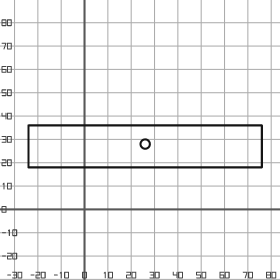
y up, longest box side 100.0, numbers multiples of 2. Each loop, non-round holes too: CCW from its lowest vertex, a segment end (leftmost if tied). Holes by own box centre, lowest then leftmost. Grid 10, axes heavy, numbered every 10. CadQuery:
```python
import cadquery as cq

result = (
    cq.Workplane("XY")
    .moveTo(-24.0, 18.0)
    .lineTo(76.0, 18.0)
    .lineTo(76.0, 36.0)
    .lineTo(-24.0, 36.0)
    .close()
    .moveTo(26.0, 28.0)
    .circle(2.0)
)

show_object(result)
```